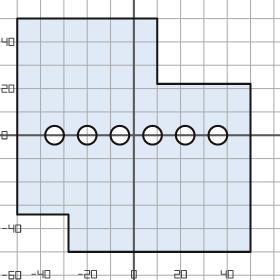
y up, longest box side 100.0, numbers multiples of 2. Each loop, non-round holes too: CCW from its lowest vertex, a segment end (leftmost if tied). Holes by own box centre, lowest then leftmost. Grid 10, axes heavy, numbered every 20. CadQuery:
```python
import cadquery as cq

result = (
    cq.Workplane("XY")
    .moveTo(-28.0, -50.0)
    .lineTo(50.0, -50.0)
    .lineTo(50.0, 22.0)
    .lineTo(10.0, 22.0)
    .lineTo(10.0, 50.0)
    .lineTo(-50.0, 50.0)
    .lineTo(-50.0, -34.0)
    .lineTo(-28.0, -34.0)
    .close()
    .moveTo(-34.0, 0.0)
    .circle(4.0)
    .moveTo(-20.0, 0.0)
    .circle(4.0)
    .moveTo(-6.0, 0.0)
    .circle(4.0)
    .moveTo(8.0, 0.0)
    .circle(4.0)
    .moveTo(22.0, 0.0)
    .circle(4.0)
    .moveTo(36.0, 0.0)
    .circle(4.0)
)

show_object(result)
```